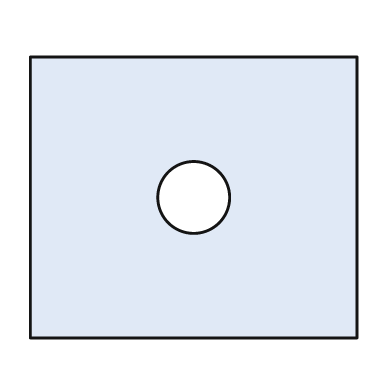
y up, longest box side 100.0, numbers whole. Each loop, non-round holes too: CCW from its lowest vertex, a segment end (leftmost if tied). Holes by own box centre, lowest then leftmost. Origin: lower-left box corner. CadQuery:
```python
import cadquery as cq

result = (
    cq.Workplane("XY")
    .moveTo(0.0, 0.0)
    .lineTo(100.0, 0.0)
    .lineTo(100.0, 86.0)
    .lineTo(0.0, 86.0)
    .close()
    .moveTo(50.0, 43.0)
    .circle(11.0)
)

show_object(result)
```